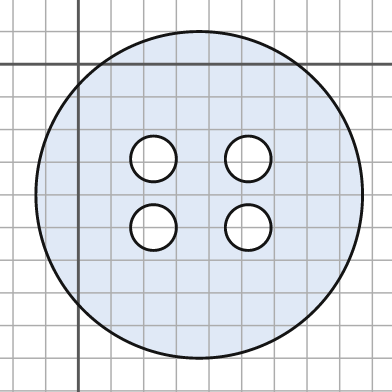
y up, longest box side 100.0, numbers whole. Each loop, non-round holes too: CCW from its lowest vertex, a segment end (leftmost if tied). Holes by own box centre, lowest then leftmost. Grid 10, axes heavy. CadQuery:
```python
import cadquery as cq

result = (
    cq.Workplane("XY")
    .moveTo(37.0, -40.0)
    .circle(50.0)
    .moveTo(23.0, -50.0)
    .circle(7.0)
    .moveTo(52.0, -50.0)
    .circle(7.0)
    .moveTo(23.0, -29.0)
    .circle(7.0)
    .moveTo(52.0, -29.0)
    .circle(7.0)
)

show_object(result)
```